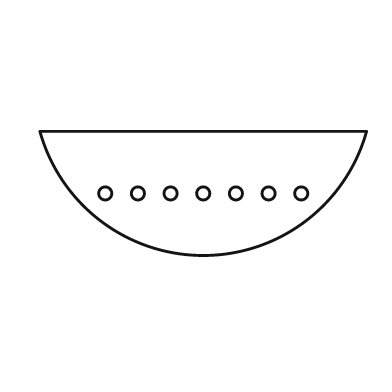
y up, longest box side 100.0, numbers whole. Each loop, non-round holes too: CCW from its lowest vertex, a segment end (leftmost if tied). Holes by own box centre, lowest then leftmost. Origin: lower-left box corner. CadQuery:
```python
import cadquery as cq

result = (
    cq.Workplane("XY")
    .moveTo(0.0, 38.0)
    .threePointArc((50.0, 0.0), (100.0, 38.0))
    .close()
    .moveTo(20.0, 19.0)
    .circle(2.0)
    .moveTo(30.0, 19.0)
    .circle(2.0)
    .moveTo(40.0, 19.0)
    .circle(2.0)
    .moveTo(50.0, 19.0)
    .circle(2.0)
    .moveTo(60.0, 19.0)
    .circle(2.0)
    .moveTo(70.0, 19.0)
    .circle(2.0)
    .moveTo(80.0, 19.0)
    .circle(2.0)
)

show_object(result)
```